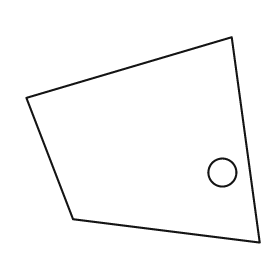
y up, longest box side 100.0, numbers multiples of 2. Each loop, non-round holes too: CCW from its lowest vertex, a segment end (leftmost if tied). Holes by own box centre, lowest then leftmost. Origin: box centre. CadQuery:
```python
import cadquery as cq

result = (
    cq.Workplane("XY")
    .moveTo(50.0, -44.0)
    .lineTo(38.0, 44.0)
    .lineTo(-50.0, 18.0)
    .lineTo(-30.0, -34.0)
    .close()
    .moveTo(34.0, -14.0)
    .circle(6.0)
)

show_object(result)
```